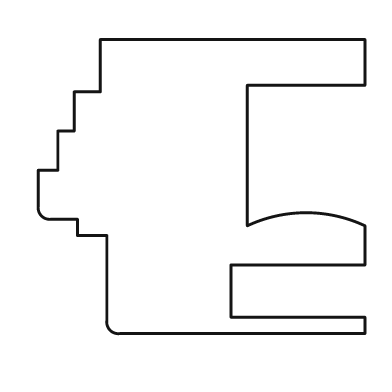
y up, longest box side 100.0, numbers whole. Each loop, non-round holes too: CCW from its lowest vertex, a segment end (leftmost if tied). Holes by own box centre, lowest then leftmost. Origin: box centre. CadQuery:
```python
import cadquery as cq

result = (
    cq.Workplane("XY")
    .moveTo(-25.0, -45.0)
    .lineTo(50.0, -45.0)
    .lineTo(50.0, -40.0)
    .lineTo(9.0, -40.0)
    .lineTo(9.0, -24.0)
    .lineTo(50.0, -24.0)
    .lineTo(50.0, -12.0)
    .threePointArc((32.0, -8.0), (14.0, -12.0))
    .lineTo(14.0, 31.0)
    .lineTo(50.0, 31.0)
    .lineTo(50.0, 45.0)
    .lineTo(-31.0, 45.0)
    .lineTo(-31.0, 29.0)
    .lineTo(-39.0, 29.0)
    .lineTo(-39.0, 17.0)
    .lineTo(-44.0, 17.0)
    .lineTo(-44.0, 5.0)
    .lineTo(-50.0, 5.0)
    .lineTo(-50.0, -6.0)
    .threePointArc((-49.0, -9.0), (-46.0, -10.0))
    .lineTo(-38.0, -10.0)
    .lineTo(-38.0, -15.0)
    .lineTo(-29.0, -15.0)
    .lineTo(-29.0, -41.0)
    .threePointArc((-28.0, -44.0), (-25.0, -45.0))
    .close()
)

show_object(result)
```